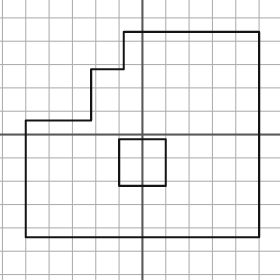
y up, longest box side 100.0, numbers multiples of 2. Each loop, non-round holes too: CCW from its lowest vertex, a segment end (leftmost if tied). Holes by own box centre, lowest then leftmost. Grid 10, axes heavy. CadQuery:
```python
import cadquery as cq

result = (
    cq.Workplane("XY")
    .moveTo(-50.0, -44.0)
    .lineTo(50.0, -44.0)
    .lineTo(50.0, 44.0)
    .lineTo(-8.0, 44.0)
    .lineTo(-8.0, 28.0)
    .lineTo(-22.0, 28.0)
    .lineTo(-22.0, 6.0)
    .lineTo(-50.0, 6.0)
    .close()
    .moveTo(-10.0, -22.0)
    .lineTo(10.0, -22.0)
    .lineTo(10.0, -2.0)
    .lineTo(-10.0, -2.0)
    .close()
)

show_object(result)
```